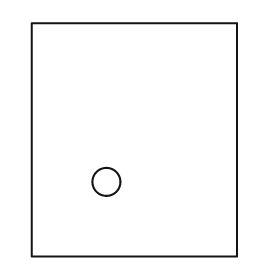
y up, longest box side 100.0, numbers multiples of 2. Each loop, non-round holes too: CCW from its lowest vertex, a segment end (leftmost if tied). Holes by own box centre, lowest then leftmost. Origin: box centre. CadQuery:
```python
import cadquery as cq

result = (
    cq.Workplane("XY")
    .moveTo(-44.0, -50.0)
    .lineTo(44.0, -50.0)
    .lineTo(44.0, 50.0)
    .lineTo(-44.0, 50.0)
    .close()
    .moveTo(-12.0, -18.0)
    .circle(6.0)
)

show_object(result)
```